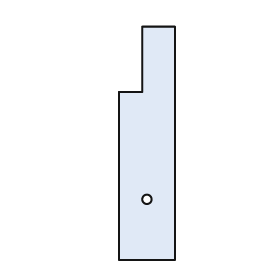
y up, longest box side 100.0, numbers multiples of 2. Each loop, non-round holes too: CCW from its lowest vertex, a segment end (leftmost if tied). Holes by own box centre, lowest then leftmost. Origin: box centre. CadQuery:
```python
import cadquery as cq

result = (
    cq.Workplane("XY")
    .moveTo(-12.0, -50.0)
    .lineTo(12.0, -50.0)
    .lineTo(12.0, 50.0)
    .lineTo(-2.0, 50.0)
    .lineTo(-2.0, 22.0)
    .lineTo(-12.0, 22.0)
    .close()
    .moveTo(0.0, -24.0)
    .circle(2.0)
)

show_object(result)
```